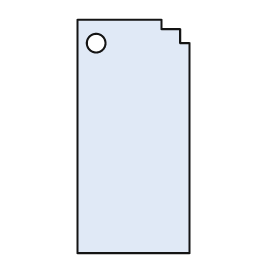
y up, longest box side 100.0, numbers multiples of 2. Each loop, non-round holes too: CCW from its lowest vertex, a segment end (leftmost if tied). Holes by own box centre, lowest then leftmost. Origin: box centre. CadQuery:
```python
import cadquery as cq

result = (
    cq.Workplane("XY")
    .moveTo(-24.0, -50.0)
    .lineTo(24.0, -50.0)
    .lineTo(24.0, 40.0)
    .lineTo(20.0, 40.0)
    .lineTo(20.0, 46.0)
    .lineTo(12.0, 46.0)
    .lineTo(12.0, 50.0)
    .lineTo(-24.0, 50.0)
    .close()
    .moveTo(-16.0, 40.0)
    .circle(4.0)
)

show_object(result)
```